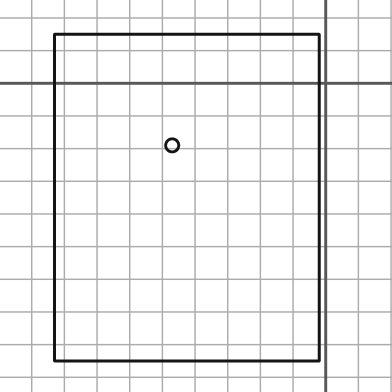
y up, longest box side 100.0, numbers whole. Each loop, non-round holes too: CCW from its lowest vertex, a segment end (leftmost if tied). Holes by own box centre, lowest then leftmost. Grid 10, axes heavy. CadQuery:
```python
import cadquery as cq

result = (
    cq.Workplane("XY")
    .moveTo(-83.0, -85.0)
    .lineTo(-2.0, -85.0)
    .lineTo(-2.0, 15.0)
    .lineTo(-83.0, 15.0)
    .close()
    .moveTo(-47.0, -19.0)
    .circle(2.0)
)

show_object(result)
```